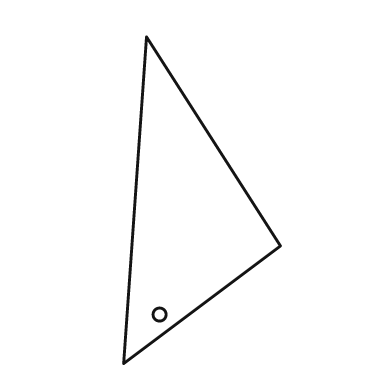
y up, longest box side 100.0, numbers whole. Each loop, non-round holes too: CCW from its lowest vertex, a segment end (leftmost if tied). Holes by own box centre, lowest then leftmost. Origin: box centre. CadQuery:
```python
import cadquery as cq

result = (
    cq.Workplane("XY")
    .moveTo(-24.0, -50.0)
    .lineTo(24.0, -14.0)
    .lineTo(-17.0, 50.0)
    .close()
    .moveTo(-13.0, -35.0)
    .circle(2.0)
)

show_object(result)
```